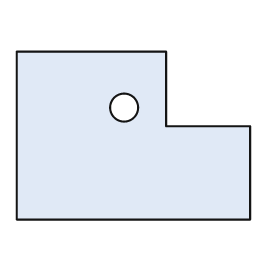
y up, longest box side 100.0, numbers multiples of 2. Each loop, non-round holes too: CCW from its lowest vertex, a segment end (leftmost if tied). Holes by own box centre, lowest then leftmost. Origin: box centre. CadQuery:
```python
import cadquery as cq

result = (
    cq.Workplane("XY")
    .moveTo(-50.0, -36.0)
    .lineTo(50.0, -36.0)
    .lineTo(50.0, 4.0)
    .lineTo(14.0, 4.0)
    .lineTo(14.0, 36.0)
    .lineTo(-50.0, 36.0)
    .close()
    .moveTo(-4.0, 12.0)
    .circle(6.0)
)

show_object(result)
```